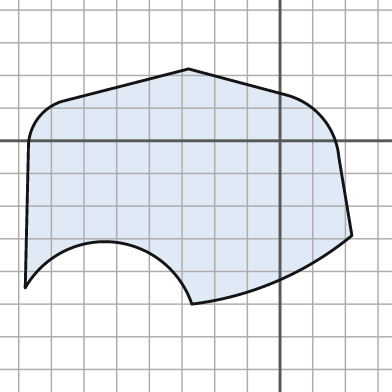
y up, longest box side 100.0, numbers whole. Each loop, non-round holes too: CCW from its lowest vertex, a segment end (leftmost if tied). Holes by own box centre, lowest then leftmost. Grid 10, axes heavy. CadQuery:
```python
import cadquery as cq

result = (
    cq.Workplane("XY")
    .moveTo(-27.0, -50.0)
    .threePointArc((-1.0, -43.0), (22.0, -29.0))
    .lineTo(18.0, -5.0)
    .threePointArc((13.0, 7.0), (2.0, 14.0))
    .lineTo(-28.0, 22.0)
    .lineTo(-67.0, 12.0)
    .threePointArc((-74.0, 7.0), (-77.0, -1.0))
    .lineTo(-78.0, -45.0)
    .threePointArc((-51.0, -31.0), (-27.0, -50.0))
    .close()
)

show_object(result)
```